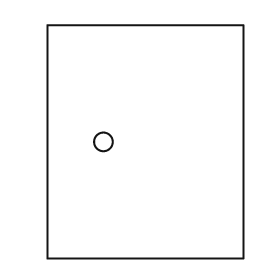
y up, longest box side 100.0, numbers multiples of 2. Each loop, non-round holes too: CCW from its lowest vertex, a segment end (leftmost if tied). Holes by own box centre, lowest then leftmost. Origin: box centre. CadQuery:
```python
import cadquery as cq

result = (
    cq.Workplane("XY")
    .moveTo(-42.0, -50.0)
    .lineTo(42.0, -50.0)
    .lineTo(42.0, 50.0)
    .lineTo(-42.0, 50.0)
    .close()
    .moveTo(-18.0, 0.0)
    .circle(4.0)
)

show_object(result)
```